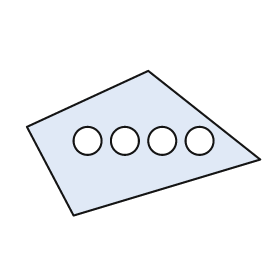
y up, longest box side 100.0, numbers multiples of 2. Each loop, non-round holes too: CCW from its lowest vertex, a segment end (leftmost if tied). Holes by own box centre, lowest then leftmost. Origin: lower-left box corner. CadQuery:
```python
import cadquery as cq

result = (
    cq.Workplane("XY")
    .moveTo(20.0, 0.0)
    .lineTo(100.0, 24.0)
    .lineTo(52.0, 62.0)
    .lineTo(0.0, 38.0)
    .close()
    .moveTo(26.0, 32.0)
    .circle(6.0)
    .moveTo(42.0, 32.0)
    .circle(6.0)
    .moveTo(58.0, 32.0)
    .circle(6.0)
    .moveTo(74.0, 32.0)
    .circle(6.0)
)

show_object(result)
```